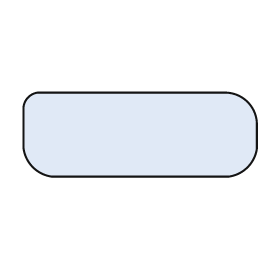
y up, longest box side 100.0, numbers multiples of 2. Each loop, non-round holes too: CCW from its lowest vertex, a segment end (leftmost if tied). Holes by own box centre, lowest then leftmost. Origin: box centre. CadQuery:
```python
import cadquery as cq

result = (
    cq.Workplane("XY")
    .moveTo(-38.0, -18.0)
    .lineTo(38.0, -18.0)
    .threePointArc((46.0, -14.0), (50.0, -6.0))
    .lineTo(50.0, 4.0)
    .threePointArc((46.0, 14.0), (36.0, 18.0))
    .lineTo(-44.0, 18.0)
    .threePointArc((-48.0, 16.0), (-50.0, 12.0))
    .lineTo(-50.0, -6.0)
    .threePointArc((-46.0, -14.0), (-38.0, -18.0))
    .close()
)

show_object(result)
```